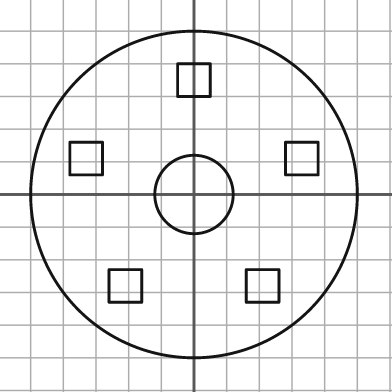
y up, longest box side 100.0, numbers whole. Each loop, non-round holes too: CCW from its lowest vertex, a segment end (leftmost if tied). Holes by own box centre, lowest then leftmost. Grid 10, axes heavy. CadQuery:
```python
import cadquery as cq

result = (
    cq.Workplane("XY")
    .moveTo(0.0, 0.0)
    .circle(50.0)
    .moveTo(-26.0, -33.0)
    .lineTo(-16.0, -33.0)
    .lineTo(-16.0, -23.0)
    .lineTo(-26.0, -23.0)
    .close()
    .moveTo(16.0, -33.0)
    .lineTo(26.0, -33.0)
    .lineTo(26.0, -23.0)
    .lineTo(16.0, -23.0)
    .close()
    .moveTo(0.0, 0.0)
    .circle(12.0)
    .moveTo(-38.0, 6.0)
    .lineTo(-28.0, 6.0)
    .lineTo(-28.0, 16.0)
    .lineTo(-38.0, 16.0)
    .close()
    .moveTo(28.0, 6.0)
    .lineTo(38.0, 6.0)
    .lineTo(38.0, 16.0)
    .lineTo(28.0, 16.0)
    .close()
    .moveTo(-5.0, 30.0)
    .lineTo(5.0, 30.0)
    .lineTo(5.0, 40.0)
    .lineTo(-5.0, 40.0)
    .close()
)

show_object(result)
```